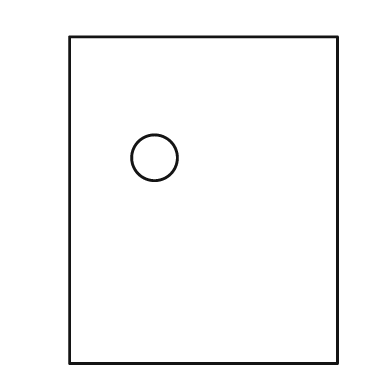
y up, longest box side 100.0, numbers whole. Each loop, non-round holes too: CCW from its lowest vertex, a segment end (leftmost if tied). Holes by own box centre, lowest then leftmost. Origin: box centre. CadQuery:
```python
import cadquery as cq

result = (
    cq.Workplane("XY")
    .moveTo(-41.0, -50.0)
    .lineTo(41.0, -50.0)
    .lineTo(41.0, 50.0)
    .lineTo(-41.0, 50.0)
    .close()
    .moveTo(-15.0, 13.0)
    .circle(7.0)
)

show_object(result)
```